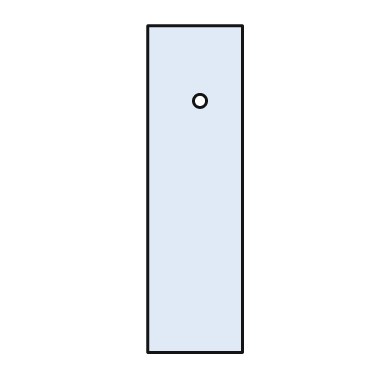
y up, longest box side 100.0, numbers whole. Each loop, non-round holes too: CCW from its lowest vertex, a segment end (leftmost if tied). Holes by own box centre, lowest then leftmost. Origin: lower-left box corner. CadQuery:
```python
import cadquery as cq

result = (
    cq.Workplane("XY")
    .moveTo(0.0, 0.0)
    .lineTo(29.0, 0.0)
    .lineTo(29.0, 100.0)
    .lineTo(0.0, 100.0)
    .close()
    .moveTo(16.0, 77.0)
    .circle(2.0)
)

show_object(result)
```